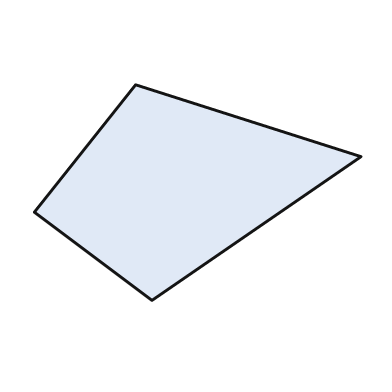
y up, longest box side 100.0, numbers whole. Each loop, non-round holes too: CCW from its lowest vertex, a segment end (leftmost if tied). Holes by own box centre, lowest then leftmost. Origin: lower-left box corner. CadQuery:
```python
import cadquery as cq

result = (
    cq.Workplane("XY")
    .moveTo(36.0, 0.0)
    .lineTo(100.0, 44.0)
    .lineTo(31.0, 66.0)
    .lineTo(0.0, 27.0)
    .close()
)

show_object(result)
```